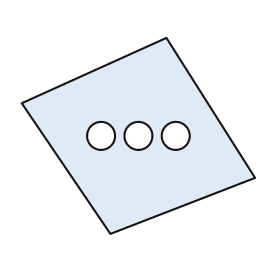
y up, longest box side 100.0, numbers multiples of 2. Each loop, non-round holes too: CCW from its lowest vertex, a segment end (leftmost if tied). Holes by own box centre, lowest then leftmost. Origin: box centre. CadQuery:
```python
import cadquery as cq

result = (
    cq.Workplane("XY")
    .moveTo(-12.0, -42.0)
    .lineTo(50.0, -18.0)
    .lineTo(12.0, 42.0)
    .lineTo(-50.0, 14.0)
    .close()
    .moveTo(-16.0, 0.0)
    .circle(6.0)
    .moveTo(0.0, 0.0)
    .circle(6.0)
    .moveTo(16.0, 0.0)
    .circle(6.0)
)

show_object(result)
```